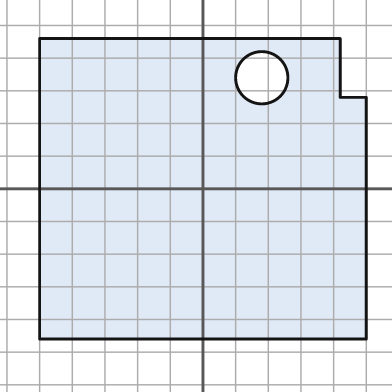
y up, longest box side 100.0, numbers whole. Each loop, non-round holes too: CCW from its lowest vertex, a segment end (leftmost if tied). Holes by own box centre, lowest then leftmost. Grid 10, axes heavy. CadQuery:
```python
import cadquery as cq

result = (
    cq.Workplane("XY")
    .moveTo(-50.0, -46.0)
    .lineTo(50.0, -46.0)
    .lineTo(50.0, 28.0)
    .lineTo(42.0, 28.0)
    .lineTo(42.0, 46.0)
    .lineTo(-50.0, 46.0)
    .close()
    .moveTo(18.0, 34.0)
    .circle(8.0)
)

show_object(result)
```